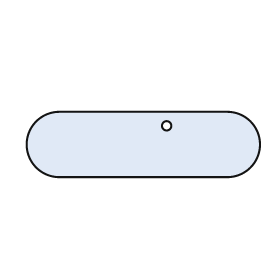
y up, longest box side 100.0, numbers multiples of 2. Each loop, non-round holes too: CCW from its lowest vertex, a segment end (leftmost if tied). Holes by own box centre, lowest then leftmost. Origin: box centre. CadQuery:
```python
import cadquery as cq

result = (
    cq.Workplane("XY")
    .moveTo(-36.0, -14.0)
    .lineTo(36.0, -14.0)
    .threePointArc((50.0, 0.0), (36.0, 14.0))
    .lineTo(-36.0, 14.0)
    .threePointArc((-50.0, 0.0), (-36.0, -14.0))
    .close()
    .moveTo(10.0, 8.0)
    .circle(2.0)
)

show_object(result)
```